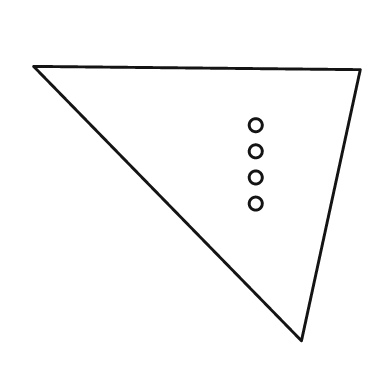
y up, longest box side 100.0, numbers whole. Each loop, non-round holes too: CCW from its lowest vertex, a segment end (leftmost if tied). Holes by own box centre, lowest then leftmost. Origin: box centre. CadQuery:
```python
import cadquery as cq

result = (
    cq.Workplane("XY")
    .moveTo(32.0, -42.0)
    .lineTo(50.0, 41.0)
    .lineTo(-50.0, 42.0)
    .close()
    .moveTo(18.0, 0.0)
    .circle(2.0)
    .moveTo(18.0, 8.0)
    .circle(2.0)
    .moveTo(18.0, 16.0)
    .circle(2.0)
    .moveTo(18.0, 24.0)
    .circle(2.0)
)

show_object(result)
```